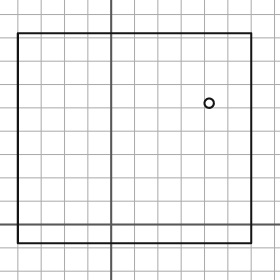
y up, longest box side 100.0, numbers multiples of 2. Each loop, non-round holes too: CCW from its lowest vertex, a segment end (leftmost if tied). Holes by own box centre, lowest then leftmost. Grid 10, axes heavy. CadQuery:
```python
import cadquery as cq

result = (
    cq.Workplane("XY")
    .moveTo(-40.0, -8.0)
    .lineTo(60.0, -8.0)
    .lineTo(60.0, 82.0)
    .lineTo(-40.0, 82.0)
    .close()
    .moveTo(42.0, 52.0)
    .circle(2.0)
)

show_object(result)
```